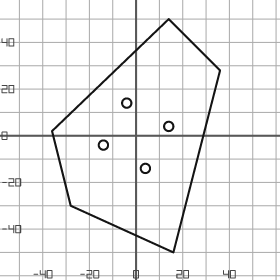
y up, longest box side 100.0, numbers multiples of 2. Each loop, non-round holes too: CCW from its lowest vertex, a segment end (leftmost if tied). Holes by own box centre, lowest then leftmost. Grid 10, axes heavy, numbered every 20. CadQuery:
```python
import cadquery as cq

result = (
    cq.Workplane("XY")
    .moveTo(16.0, -50.0)
    .lineTo(36.0, 28.0)
    .lineTo(14.0, 50.0)
    .lineTo(-36.0, 2.0)
    .lineTo(-28.0, -30.0)
    .close()
    .moveTo(4.0, -14.0)
    .circle(2.0)
    .moveTo(-14.0, -4.0)
    .circle(2.0)
    .moveTo(14.0, 4.0)
    .circle(2.0)
    .moveTo(-4.0, 14.0)
    .circle(2.0)
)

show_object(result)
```